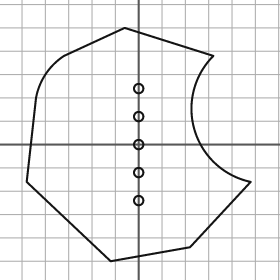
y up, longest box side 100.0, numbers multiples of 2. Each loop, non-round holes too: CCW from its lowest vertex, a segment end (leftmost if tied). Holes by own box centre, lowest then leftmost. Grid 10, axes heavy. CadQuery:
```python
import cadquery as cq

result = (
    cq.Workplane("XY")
    .moveTo(-12.0, -50.0)
    .lineTo(22.0, -44.0)
    .lineTo(48.0, -16.0)
    .threePointArc((24.0, 6.0), (32.0, 38.0))
    .lineTo(-6.0, 50.0)
    .lineTo(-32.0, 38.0)
    .threePointArc((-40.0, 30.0), (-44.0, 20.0))
    .lineTo(-48.0, -16.0)
    .close()
    .moveTo(0.0, -24.0)
    .circle(2.0)
    .moveTo(0.0, -12.0)
    .circle(2.0)
    .moveTo(0.0, 0.0)
    .circle(2.0)
    .moveTo(0.0, 12.0)
    .circle(2.0)
    .moveTo(0.0, 24.0)
    .circle(2.0)
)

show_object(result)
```